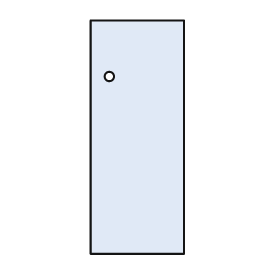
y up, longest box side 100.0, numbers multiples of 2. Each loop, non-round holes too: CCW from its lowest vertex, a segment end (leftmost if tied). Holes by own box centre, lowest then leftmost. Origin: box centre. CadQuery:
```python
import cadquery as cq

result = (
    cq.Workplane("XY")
    .moveTo(-20.0, -50.0)
    .lineTo(20.0, -50.0)
    .lineTo(20.0, 50.0)
    .lineTo(-20.0, 50.0)
    .close()
    .moveTo(-12.0, 26.0)
    .circle(2.0)
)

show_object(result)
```